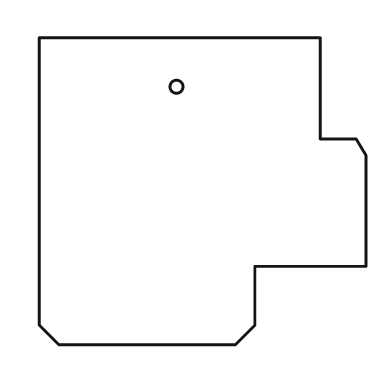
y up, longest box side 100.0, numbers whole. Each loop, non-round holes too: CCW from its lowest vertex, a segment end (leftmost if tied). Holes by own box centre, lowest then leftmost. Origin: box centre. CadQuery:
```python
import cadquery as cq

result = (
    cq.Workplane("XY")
    .moveTo(-44.0, -47.0)
    .lineTo(10.0, -47.0)
    .lineTo(16.0, -41.0)
    .lineTo(16.0, -23.0)
    .lineTo(50.0, -23.0)
    .lineTo(50.0, 11.0)
    .lineTo(47.0, 16.0)
    .lineTo(36.0, 16.0)
    .lineTo(36.0, 47.0)
    .lineTo(-50.0, 47.0)
    .lineTo(-50.0, -41.0)
    .close()
    .moveTo(-8.0, 32.0)
    .circle(2.0)
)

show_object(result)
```